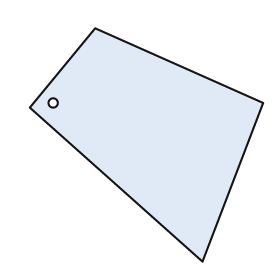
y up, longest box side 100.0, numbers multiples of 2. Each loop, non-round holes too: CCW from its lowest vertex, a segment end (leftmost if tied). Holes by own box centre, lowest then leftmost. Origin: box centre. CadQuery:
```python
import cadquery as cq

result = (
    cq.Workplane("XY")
    .moveTo(24.0, -50.0)
    .lineTo(50.0, 18.0)
    .lineTo(-22.0, 50.0)
    .lineTo(-50.0, 16.0)
    .close()
    .moveTo(-40.0, 18.0)
    .circle(2.0)
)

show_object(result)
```